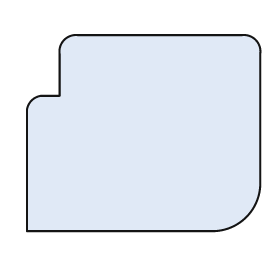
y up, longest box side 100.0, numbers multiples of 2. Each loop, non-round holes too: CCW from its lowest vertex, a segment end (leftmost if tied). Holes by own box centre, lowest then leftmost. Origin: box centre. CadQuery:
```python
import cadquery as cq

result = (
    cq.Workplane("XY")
    .moveTo(-50.0, -42.0)
    .lineTo(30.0, -42.0)
    .threePointArc((44.0, -36.0), (50.0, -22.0))
    .lineTo(50.0, 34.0)
    .threePointArc((48.0, 40.0), (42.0, 42.0))
    .lineTo(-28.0, 42.0)
    .threePointArc((-34.0, 40.0), (-36.0, 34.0))
    .lineTo(-36.0, 16.0)
    .lineTo(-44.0, 16.0)
    .threePointArc((-48.0, 14.0), (-50.0, 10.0))
    .close()
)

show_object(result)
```